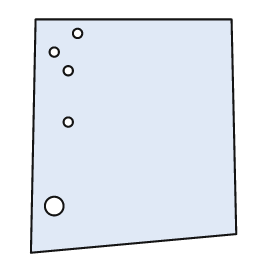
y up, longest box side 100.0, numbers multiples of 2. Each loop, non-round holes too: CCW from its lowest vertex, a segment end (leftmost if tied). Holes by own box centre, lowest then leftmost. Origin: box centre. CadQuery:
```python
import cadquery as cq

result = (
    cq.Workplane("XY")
    .moveTo(-44.0, -50.0)
    .lineTo(44.0, -42.0)
    .lineTo(42.0, 50.0)
    .lineTo(-42.0, 50.0)
    .close()
    .moveTo(-34.0, -30.0)
    .circle(4.0)
    .moveTo(-28.0, 6.0)
    .circle(2.0)
    .moveTo(-28.0, 28.0)
    .circle(2.0)
    .moveTo(-34.0, 36.0)
    .circle(2.0)
    .moveTo(-24.0, 44.0)
    .circle(2.0)
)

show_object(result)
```